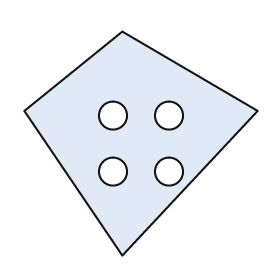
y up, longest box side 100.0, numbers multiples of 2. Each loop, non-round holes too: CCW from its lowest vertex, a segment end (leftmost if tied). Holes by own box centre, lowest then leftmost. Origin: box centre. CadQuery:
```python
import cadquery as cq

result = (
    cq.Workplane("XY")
    .moveTo(-8.0, -48.0)
    .lineTo(50.0, 14.0)
    .lineTo(-8.0, 48.0)
    .lineTo(-50.0, 14.0)
    .close()
    .moveTo(-12.0, -12.0)
    .circle(6.0)
    .moveTo(12.0, -12.0)
    .circle(6.0)
    .moveTo(-12.0, 12.0)
    .circle(6.0)
    .moveTo(12.0, 12.0)
    .circle(6.0)
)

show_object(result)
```